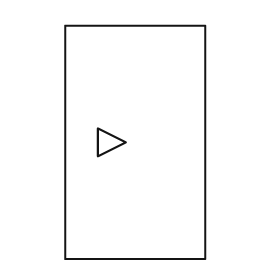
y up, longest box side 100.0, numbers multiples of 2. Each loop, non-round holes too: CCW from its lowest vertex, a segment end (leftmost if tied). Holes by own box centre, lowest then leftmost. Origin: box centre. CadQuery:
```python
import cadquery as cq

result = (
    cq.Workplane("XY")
    .moveTo(-30.0, -50.0)
    .lineTo(30.0, -50.0)
    .lineTo(30.0, 50.0)
    .lineTo(-30.0, 50.0)
    .close()
    .moveTo(-16.0, -6.0)
    .lineTo(-4.0, 0.0)
    .lineTo(-16.0, 6.0)
    .close()
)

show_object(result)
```